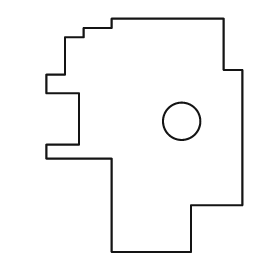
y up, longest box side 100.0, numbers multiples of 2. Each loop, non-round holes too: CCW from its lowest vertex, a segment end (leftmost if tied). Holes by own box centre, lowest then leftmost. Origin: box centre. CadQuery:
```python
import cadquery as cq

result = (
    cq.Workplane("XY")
    .moveTo(-14.0, -50.0)
    .lineTo(20.0, -50.0)
    .lineTo(20.0, -30.0)
    .lineTo(42.0, -30.0)
    .lineTo(42.0, 28.0)
    .lineTo(34.0, 28.0)
    .lineTo(34.0, 50.0)
    .lineTo(-14.0, 50.0)
    .lineTo(-14.0, 46.0)
    .lineTo(-26.0, 46.0)
    .lineTo(-26.0, 42.0)
    .lineTo(-34.0, 42.0)
    .lineTo(-34.0, 26.0)
    .lineTo(-42.0, 26.0)
    .lineTo(-42.0, 18.0)
    .lineTo(-28.0, 18.0)
    .lineTo(-28.0, -4.0)
    .lineTo(-42.0, -4.0)
    .lineTo(-42.0, -10.0)
    .lineTo(-14.0, -10.0)
    .close()
    .moveTo(16.0, 6.0)
    .circle(8.0)
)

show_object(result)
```